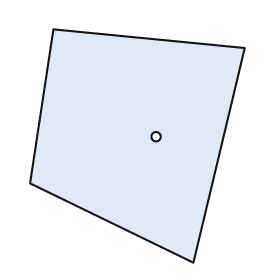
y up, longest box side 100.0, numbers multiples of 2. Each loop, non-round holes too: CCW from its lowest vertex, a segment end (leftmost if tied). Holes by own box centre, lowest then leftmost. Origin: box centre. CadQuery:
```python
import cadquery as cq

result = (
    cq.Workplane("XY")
    .moveTo(24.0, -50.0)
    .lineTo(46.0, 42.0)
    .lineTo(-36.0, 50.0)
    .lineTo(-46.0, -16.0)
    .close()
    .moveTo(8.0, 4.0)
    .circle(2.0)
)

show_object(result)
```